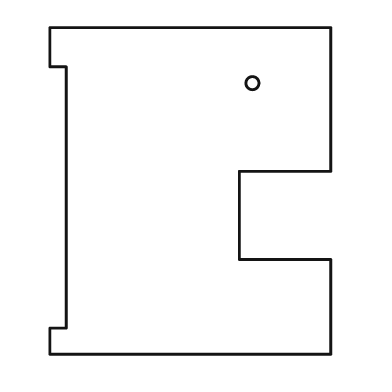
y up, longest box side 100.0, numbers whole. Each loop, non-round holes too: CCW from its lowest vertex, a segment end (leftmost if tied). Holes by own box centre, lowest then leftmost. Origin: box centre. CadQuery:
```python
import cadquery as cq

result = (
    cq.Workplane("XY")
    .moveTo(-43.0, -50.0)
    .lineTo(43.0, -50.0)
    .lineTo(43.0, -21.0)
    .lineTo(15.0, -21.0)
    .lineTo(15.0, 6.0)
    .lineTo(43.0, 6.0)
    .lineTo(43.0, 50.0)
    .lineTo(-43.0, 50.0)
    .lineTo(-43.0, 38.0)
    .lineTo(-38.0, 38.0)
    .lineTo(-38.0, -42.0)
    .lineTo(-43.0, -42.0)
    .close()
    .moveTo(19.0, 33.0)
    .circle(2.0)
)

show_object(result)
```